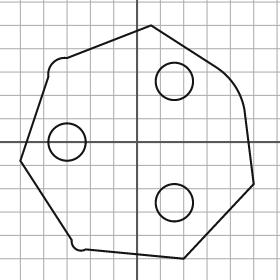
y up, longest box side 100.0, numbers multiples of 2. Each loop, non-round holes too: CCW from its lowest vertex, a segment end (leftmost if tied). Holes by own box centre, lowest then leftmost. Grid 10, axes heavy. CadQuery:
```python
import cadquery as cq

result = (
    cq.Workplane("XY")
    .moveTo(20.0, -50.0)
    .lineTo(50.0, -18.0)
    .lineTo(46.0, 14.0)
    .threePointArc((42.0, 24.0), (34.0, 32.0))
    .lineTo(6.0, 50.0)
    .lineTo(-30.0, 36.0)
    .threePointArc((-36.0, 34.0), (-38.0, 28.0))
    .lineTo(-50.0, -8.0)
    .lineTo(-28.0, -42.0)
    .threePointArc((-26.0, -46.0), (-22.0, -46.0))
    .close()
    .moveTo(16.0, -26.0)
    .circle(8.0)
    .moveTo(-30.0, 0.0)
    .circle(8.0)
    .moveTo(16.0, 26.0)
    .circle(8.0)
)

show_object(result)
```